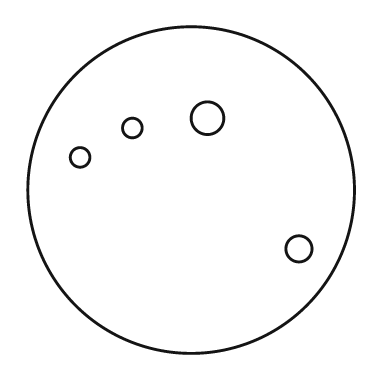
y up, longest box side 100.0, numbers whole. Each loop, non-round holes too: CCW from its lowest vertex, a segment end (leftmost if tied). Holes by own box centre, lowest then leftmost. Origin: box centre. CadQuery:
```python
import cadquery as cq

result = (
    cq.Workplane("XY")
    .moveTo(0.0, 0.0)
    .circle(50.0)
    .moveTo(33.0, -18.0)
    .circle(4.0)
    .moveTo(-34.0, 10.0)
    .circle(3.0)
    .moveTo(-18.0, 19.0)
    .circle(3.0)
    .moveTo(5.0, 22.0)
    .circle(5.0)
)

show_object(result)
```